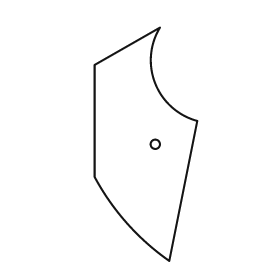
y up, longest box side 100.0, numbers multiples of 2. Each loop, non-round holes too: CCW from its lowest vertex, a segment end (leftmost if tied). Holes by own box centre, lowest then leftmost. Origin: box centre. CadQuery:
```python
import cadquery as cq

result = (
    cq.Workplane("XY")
    .moveTo(10.0, -50.0)
    .lineTo(22.0, 10.0)
    .threePointArc((4.0, 26.0), (6.0, 50.0))
    .lineTo(-22.0, 34.0)
    .lineTo(-22.0, -14.0)
    .threePointArc((-8.0, -34.0), (10.0, -50.0))
    .close()
    .moveTo(4.0, 0.0)
    .circle(2.0)
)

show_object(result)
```